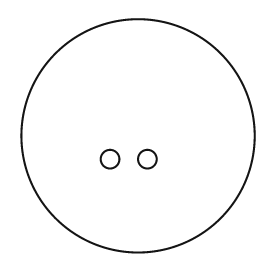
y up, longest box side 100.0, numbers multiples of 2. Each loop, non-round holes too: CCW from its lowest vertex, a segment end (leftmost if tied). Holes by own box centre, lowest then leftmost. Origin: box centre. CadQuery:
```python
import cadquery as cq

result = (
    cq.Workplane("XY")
    .moveTo(0.0, 0.0)
    .circle(50.0)
    .moveTo(-12.0, -10.0)
    .circle(4.0)
    .moveTo(4.0, -10.0)
    .circle(4.0)
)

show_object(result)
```